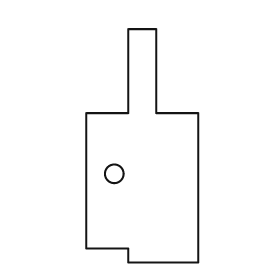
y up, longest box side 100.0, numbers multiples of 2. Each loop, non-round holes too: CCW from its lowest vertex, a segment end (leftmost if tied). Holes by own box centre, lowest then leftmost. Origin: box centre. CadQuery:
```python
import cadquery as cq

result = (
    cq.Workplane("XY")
    .moveTo(-6.0, -50.0)
    .lineTo(24.0, -50.0)
    .lineTo(24.0, 14.0)
    .lineTo(6.0, 14.0)
    .lineTo(6.0, 50.0)
    .lineTo(-6.0, 50.0)
    .lineTo(-6.0, 14.0)
    .lineTo(-24.0, 14.0)
    .lineTo(-24.0, -44.0)
    .lineTo(-6.0, -44.0)
    .close()
    .moveTo(-12.0, -12.0)
    .circle(4.0)
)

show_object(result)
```